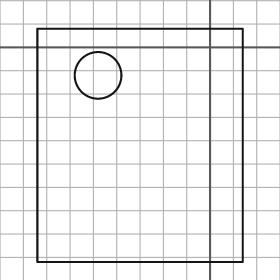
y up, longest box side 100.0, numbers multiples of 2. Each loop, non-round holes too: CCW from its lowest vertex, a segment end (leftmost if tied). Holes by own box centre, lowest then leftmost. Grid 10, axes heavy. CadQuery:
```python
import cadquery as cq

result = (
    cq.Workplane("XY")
    .moveTo(-74.0, -92.0)
    .lineTo(14.0, -92.0)
    .lineTo(14.0, 8.0)
    .lineTo(-74.0, 8.0)
    .close()
    .moveTo(-48.0, -12.0)
    .circle(10.0)
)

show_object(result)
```